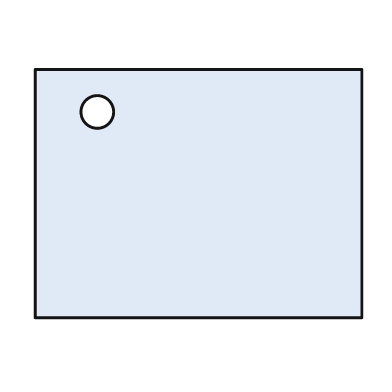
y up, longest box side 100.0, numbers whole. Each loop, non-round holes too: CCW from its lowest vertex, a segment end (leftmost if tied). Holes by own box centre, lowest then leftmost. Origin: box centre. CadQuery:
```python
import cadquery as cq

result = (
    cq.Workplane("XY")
    .moveTo(-50.0, -38.0)
    .lineTo(50.0, -38.0)
    .lineTo(50.0, 38.0)
    .lineTo(-50.0, 38.0)
    .close()
    .moveTo(-31.0, 25.0)
    .circle(5.0)
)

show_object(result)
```